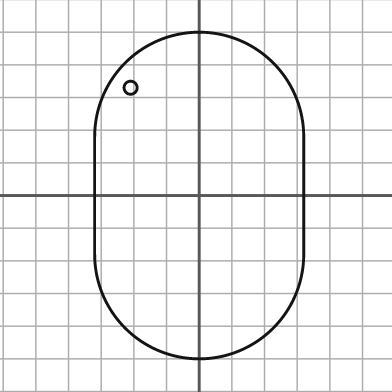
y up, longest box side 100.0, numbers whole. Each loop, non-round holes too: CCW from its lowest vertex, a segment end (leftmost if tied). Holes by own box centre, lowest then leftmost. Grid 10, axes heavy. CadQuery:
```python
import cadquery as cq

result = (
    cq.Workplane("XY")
    .moveTo(-32.0, -18.0)
    .threePointArc((0.0, -50.0), (32.0, -18.0))
    .lineTo(32.0, 18.0)
    .threePointArc((0.0, 50.0), (-32.0, 18.0))
    .close()
    .moveTo(-21.0, 33.0)
    .circle(2.0)
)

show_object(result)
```